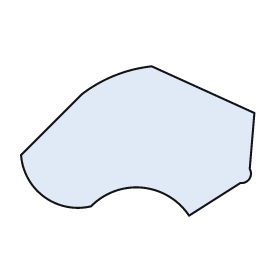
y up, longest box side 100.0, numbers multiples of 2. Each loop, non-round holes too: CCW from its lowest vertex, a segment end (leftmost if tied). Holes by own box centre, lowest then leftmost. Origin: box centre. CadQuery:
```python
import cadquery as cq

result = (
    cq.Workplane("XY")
    .moveTo(22.0, -32.0)
    .lineTo(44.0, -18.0)
    .threePointArc((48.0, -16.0), (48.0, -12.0))
    .lineTo(50.0, 12.0)
    .lineTo(6.0, 32.0)
    .threePointArc((-10.0, 28.0), (-24.0, 20.0))
    .lineTo(-50.0, -6.0)
    .threePointArc((-40.0, -24.0), (-20.0, -28.0))
    .threePointArc((2.0, -20.0), (22.0, -32.0))
    .close()
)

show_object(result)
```